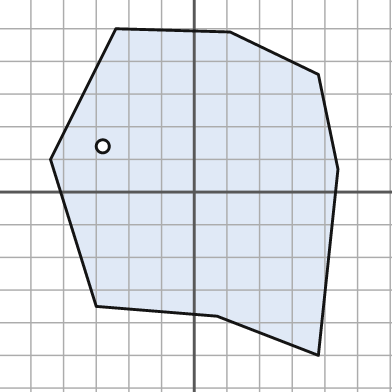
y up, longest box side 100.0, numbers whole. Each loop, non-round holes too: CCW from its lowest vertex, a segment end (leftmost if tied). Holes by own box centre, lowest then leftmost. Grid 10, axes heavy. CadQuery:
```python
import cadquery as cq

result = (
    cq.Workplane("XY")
    .moveTo(38.0, -50.0)
    .lineTo(44.0, 7.0)
    .lineTo(38.0, 36.0)
    .lineTo(11.0, 49.0)
    .lineTo(-24.0, 50.0)
    .lineTo(-44.0, 10.0)
    .lineTo(-30.0, -35.0)
    .lineTo(7.0, -38.0)
    .close()
    .moveTo(-28.0, 14.0)
    .circle(2.0)
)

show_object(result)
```